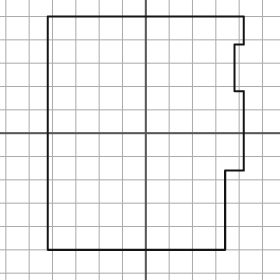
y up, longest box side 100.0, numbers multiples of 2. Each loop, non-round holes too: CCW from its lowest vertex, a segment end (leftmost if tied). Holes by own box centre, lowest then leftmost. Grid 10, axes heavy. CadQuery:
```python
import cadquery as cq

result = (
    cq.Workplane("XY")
    .moveTo(-42.0, -50.0)
    .lineTo(34.0, -50.0)
    .lineTo(34.0, -16.0)
    .lineTo(42.0, -16.0)
    .lineTo(42.0, 18.0)
    .lineTo(38.0, 18.0)
    .lineTo(38.0, 38.0)
    .lineTo(42.0, 38.0)
    .lineTo(42.0, 50.0)
    .lineTo(-42.0, 50.0)
    .close()
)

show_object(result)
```